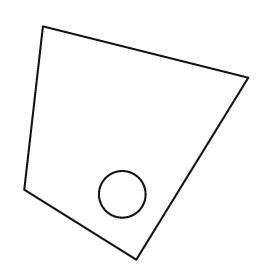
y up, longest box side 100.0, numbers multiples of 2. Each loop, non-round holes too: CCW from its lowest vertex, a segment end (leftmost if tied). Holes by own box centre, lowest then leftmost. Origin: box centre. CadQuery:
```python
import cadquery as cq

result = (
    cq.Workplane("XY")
    .moveTo(0.0, -50.0)
    .lineTo(48.0, 28.0)
    .lineTo(-40.0, 50.0)
    .lineTo(-48.0, -20.0)
    .close()
    .moveTo(-6.0, -22.0)
    .circle(10.0)
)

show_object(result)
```